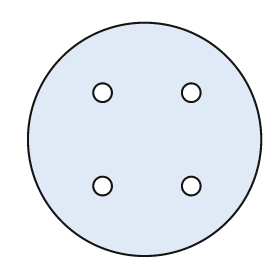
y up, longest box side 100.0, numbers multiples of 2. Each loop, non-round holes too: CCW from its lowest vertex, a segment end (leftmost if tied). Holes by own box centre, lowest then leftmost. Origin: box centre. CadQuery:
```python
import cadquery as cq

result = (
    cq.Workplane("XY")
    .moveTo(0.0, 0.0)
    .circle(50.0)
    .moveTo(-18.0, -20.0)
    .circle(4.0)
    .moveTo(20.0, -20.0)
    .circle(4.0)
    .moveTo(-18.0, 20.0)
    .circle(4.0)
    .moveTo(20.0, 20.0)
    .circle(4.0)
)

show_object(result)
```